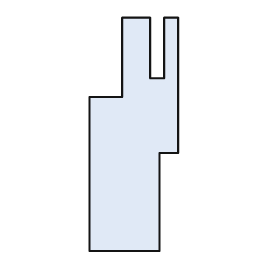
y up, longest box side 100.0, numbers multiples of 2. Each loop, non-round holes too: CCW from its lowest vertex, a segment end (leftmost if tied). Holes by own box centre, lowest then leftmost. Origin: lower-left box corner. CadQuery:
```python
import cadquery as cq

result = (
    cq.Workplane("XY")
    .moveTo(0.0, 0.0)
    .lineTo(30.0, 0.0)
    .lineTo(30.0, 42.0)
    .lineTo(38.0, 42.0)
    .lineTo(38.0, 100.0)
    .lineTo(32.0, 100.0)
    .lineTo(32.0, 74.0)
    .lineTo(26.0, 74.0)
    .lineTo(26.0, 100.0)
    .lineTo(14.0, 100.0)
    .lineTo(14.0, 66.0)
    .lineTo(0.0, 66.0)
    .close()
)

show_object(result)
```